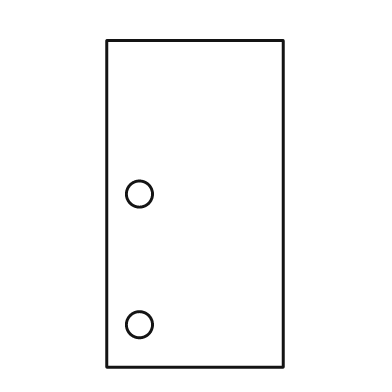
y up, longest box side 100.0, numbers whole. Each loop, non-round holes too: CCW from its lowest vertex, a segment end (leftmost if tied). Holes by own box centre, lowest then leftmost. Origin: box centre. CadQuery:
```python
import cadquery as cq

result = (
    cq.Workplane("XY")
    .moveTo(-27.0, -50.0)
    .lineTo(27.0, -50.0)
    .lineTo(27.0, 50.0)
    .lineTo(-27.0, 50.0)
    .close()
    .moveTo(-17.0, -37.0)
    .circle(4.0)
    .moveTo(-17.0, 3.0)
    .circle(4.0)
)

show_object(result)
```